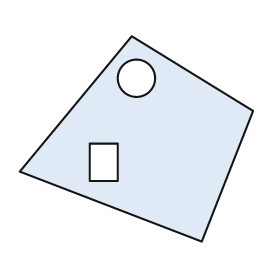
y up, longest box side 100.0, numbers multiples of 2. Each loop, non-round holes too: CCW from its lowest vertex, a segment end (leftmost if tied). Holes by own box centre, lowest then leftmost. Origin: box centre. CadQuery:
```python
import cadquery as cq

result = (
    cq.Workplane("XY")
    .moveTo(28.0, -44.0)
    .lineTo(50.0, 12.0)
    .lineTo(-2.0, 44.0)
    .lineTo(-50.0, -14.0)
    .close()
    .moveTo(-20.0, -18.0)
    .lineTo(-8.0, -18.0)
    .lineTo(-8.0, -2.0)
    .lineTo(-20.0, -2.0)
    .close()
    .moveTo(0.0, 26.0)
    .circle(8.0)
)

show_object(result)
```